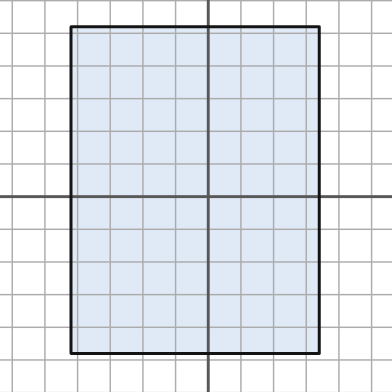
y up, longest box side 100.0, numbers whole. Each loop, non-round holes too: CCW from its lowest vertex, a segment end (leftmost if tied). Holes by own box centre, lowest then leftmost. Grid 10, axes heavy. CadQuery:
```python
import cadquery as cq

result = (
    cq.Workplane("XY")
    .moveTo(-42.0, -48.0)
    .lineTo(34.0, -48.0)
    .lineTo(34.0, 52.0)
    .lineTo(-42.0, 52.0)
    .close()
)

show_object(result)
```